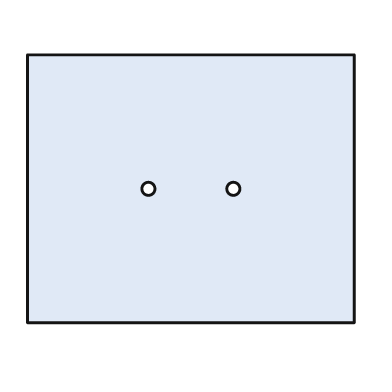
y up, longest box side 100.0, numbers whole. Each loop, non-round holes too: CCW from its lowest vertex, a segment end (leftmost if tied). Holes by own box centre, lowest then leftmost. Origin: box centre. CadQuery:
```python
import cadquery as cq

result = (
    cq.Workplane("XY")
    .moveTo(-50.0, -41.0)
    .lineTo(50.0, -41.0)
    .lineTo(50.0, 41.0)
    .lineTo(-50.0, 41.0)
    .close()
    .moveTo(-13.0, 0.0)
    .circle(2.0)
    .moveTo(13.0, 0.0)
    .circle(2.0)
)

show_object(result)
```